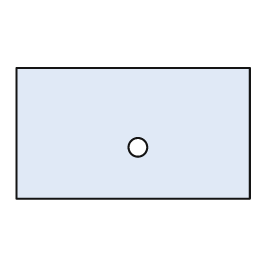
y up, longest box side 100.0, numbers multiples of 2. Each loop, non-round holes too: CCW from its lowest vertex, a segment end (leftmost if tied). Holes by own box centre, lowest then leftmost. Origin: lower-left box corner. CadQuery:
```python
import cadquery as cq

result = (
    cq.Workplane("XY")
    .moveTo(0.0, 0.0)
    .lineTo(100.0, 0.0)
    .lineTo(100.0, 56.0)
    .lineTo(0.0, 56.0)
    .close()
    .moveTo(52.0, 22.0)
    .circle(4.0)
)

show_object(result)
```